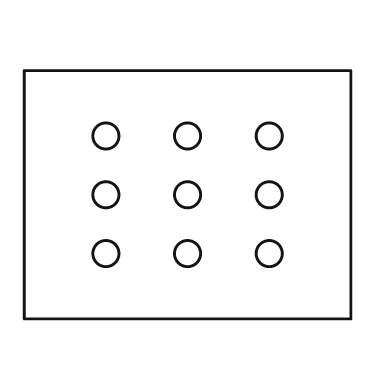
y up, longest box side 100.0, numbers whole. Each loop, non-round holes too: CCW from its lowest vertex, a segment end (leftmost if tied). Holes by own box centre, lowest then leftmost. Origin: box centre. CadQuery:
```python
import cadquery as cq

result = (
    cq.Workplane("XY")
    .moveTo(-50.0, -38.0)
    .lineTo(50.0, -38.0)
    .lineTo(50.0, 38.0)
    .lineTo(-50.0, 38.0)
    .close()
    .moveTo(-25.0, -18.0)
    .circle(4.0)
    .moveTo(0.0, -18.0)
    .circle(4.0)
    .moveTo(25.0, -18.0)
    .circle(4.0)
    .moveTo(-25.0, 0.0)
    .circle(4.0)
    .moveTo(0.0, 0.0)
    .circle(4.0)
    .moveTo(25.0, 0.0)
    .circle(4.0)
    .moveTo(-25.0, 18.0)
    .circle(4.0)
    .moveTo(0.0, 18.0)
    .circle(4.0)
    .moveTo(25.0, 18.0)
    .circle(4.0)
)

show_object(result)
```